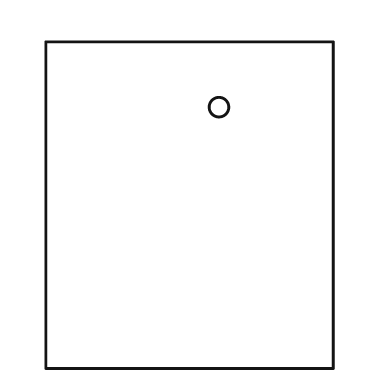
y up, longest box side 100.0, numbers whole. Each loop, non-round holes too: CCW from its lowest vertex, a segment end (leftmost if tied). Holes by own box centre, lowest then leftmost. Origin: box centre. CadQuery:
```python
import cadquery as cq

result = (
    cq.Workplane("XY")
    .moveTo(-44.0, -50.0)
    .lineTo(44.0, -50.0)
    .lineTo(44.0, 50.0)
    .lineTo(-44.0, 50.0)
    .close()
    .moveTo(9.0, 30.0)
    .circle(3.0)
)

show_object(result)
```